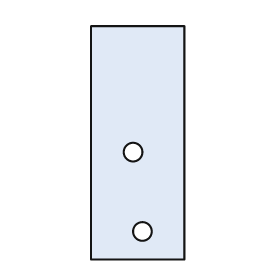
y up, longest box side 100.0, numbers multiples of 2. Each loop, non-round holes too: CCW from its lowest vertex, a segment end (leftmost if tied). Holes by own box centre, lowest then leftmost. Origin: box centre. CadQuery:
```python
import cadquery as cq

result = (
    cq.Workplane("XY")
    .moveTo(-20.0, -50.0)
    .lineTo(20.0, -50.0)
    .lineTo(20.0, 50.0)
    .lineTo(-20.0, 50.0)
    .close()
    .moveTo(2.0, -38.0)
    .circle(4.0)
    .moveTo(-2.0, -4.0)
    .circle(4.0)
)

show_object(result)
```